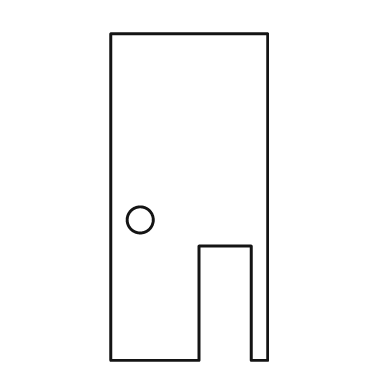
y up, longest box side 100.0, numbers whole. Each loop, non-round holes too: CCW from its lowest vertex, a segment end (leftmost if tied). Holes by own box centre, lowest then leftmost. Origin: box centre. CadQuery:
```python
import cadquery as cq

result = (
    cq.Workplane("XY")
    .moveTo(-24.0, -50.0)
    .lineTo(3.0, -50.0)
    .lineTo(3.0, -15.0)
    .lineTo(19.0, -15.0)
    .lineTo(19.0, -50.0)
    .lineTo(24.0, -50.0)
    .lineTo(24.0, 50.0)
    .lineTo(-24.0, 50.0)
    .close()
    .moveTo(-15.0, -7.0)
    .circle(4.0)
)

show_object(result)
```